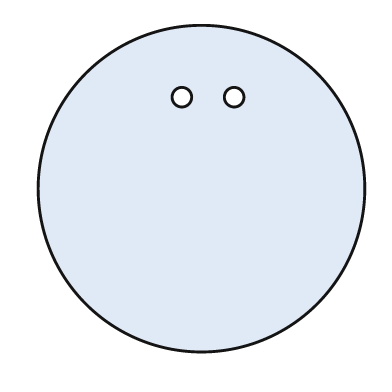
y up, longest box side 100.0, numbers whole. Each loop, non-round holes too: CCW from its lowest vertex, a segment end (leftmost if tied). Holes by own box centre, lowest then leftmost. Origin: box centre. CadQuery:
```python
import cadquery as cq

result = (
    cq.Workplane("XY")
    .moveTo(0.0, 0.0)
    .circle(50.0)
    .moveTo(-6.0, 28.0)
    .circle(3.0)
    .moveTo(10.0, 28.0)
    .circle(3.0)
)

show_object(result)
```